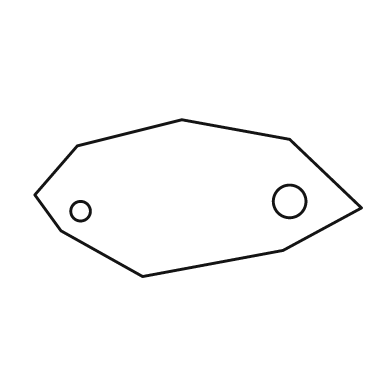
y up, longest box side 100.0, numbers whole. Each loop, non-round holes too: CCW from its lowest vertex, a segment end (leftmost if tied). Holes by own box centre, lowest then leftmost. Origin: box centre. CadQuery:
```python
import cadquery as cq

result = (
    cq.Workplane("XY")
    .moveTo(-17.0, -24.0)
    .lineTo(26.0, -16.0)
    .lineTo(50.0, -3.0)
    .lineTo(28.0, 18.0)
    .lineTo(-5.0, 24.0)
    .lineTo(-37.0, 16.0)
    .lineTo(-50.0, 1.0)
    .lineTo(-42.0, -10.0)
    .close()
    .moveTo(-36.0, -4.0)
    .circle(3.0)
    .moveTo(28.0, -1.0)
    .circle(5.0)
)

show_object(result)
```